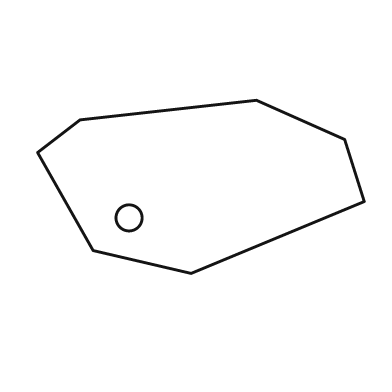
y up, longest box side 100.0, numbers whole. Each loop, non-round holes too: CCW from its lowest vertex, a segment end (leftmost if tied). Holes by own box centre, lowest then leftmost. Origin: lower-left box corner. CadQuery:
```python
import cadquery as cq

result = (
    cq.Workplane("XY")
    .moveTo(47.0, 0.0)
    .lineTo(100.0, 22.0)
    .lineTo(94.0, 41.0)
    .lineTo(67.0, 53.0)
    .lineTo(13.0, 47.0)
    .lineTo(0.0, 37.0)
    .lineTo(17.0, 7.0)
    .close()
    .moveTo(28.0, 17.0)
    .circle(4.0)
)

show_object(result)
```